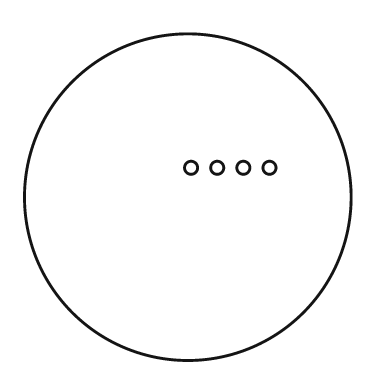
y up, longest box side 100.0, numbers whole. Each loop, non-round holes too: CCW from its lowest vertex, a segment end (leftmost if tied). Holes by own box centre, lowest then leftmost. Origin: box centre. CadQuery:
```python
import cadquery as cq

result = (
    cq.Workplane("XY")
    .moveTo(0.0, 0.0)
    .circle(50.0)
    .moveTo(1.0, 9.0)
    .circle(2.0)
    .moveTo(9.0, 9.0)
    .circle(2.0)
    .moveTo(17.0, 9.0)
    .circle(2.0)
    .moveTo(25.0, 9.0)
    .circle(2.0)
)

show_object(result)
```